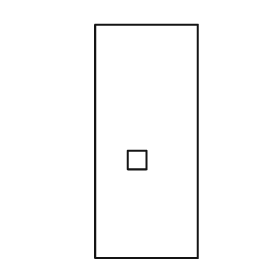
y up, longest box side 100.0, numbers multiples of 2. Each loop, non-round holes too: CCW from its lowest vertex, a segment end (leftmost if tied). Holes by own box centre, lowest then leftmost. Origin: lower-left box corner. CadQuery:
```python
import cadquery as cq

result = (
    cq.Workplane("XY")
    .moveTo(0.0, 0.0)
    .lineTo(44.0, 0.0)
    .lineTo(44.0, 100.0)
    .lineTo(0.0, 100.0)
    .close()
    .moveTo(14.0, 38.0)
    .lineTo(22.0, 38.0)
    .lineTo(22.0, 46.0)
    .lineTo(14.0, 46.0)
    .close()
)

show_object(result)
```